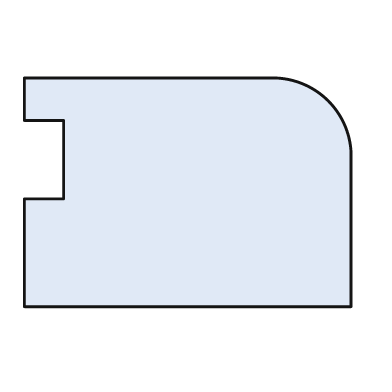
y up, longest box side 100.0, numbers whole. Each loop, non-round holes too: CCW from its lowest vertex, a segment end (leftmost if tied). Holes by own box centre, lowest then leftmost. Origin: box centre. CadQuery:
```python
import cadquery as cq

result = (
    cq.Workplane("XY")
    .moveTo(-50.0, -35.0)
    .lineTo(50.0, -35.0)
    .lineTo(50.0, 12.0)
    .threePointArc((43.0, 28.0), (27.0, 35.0))
    .lineTo(-50.0, 35.0)
    .lineTo(-50.0, 22.0)
    .lineTo(-38.0, 22.0)
    .lineTo(-38.0, -2.0)
    .lineTo(-50.0, -2.0)
    .close()
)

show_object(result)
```